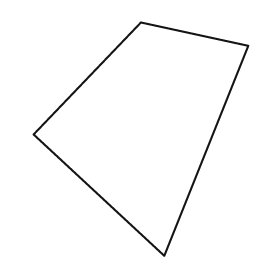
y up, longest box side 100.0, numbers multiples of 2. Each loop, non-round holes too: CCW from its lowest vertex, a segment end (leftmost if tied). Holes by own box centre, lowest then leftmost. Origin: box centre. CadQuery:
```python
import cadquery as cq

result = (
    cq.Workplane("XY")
    .moveTo(10.0, -50.0)
    .lineTo(46.0, 40.0)
    .lineTo(0.0, 50.0)
    .lineTo(-46.0, 2.0)
    .close()
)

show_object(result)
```